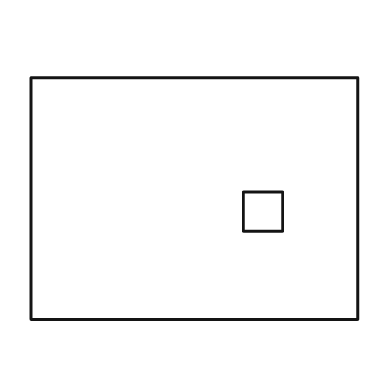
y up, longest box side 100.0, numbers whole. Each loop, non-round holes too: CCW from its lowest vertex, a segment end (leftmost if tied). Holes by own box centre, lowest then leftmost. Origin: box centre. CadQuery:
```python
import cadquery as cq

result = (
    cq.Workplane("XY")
    .moveTo(-50.0, -37.0)
    .lineTo(50.0, -37.0)
    .lineTo(50.0, 37.0)
    .lineTo(-50.0, 37.0)
    .close()
    .moveTo(15.0, -10.0)
    .lineTo(27.0, -10.0)
    .lineTo(27.0, 2.0)
    .lineTo(15.0, 2.0)
    .close()
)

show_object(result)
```